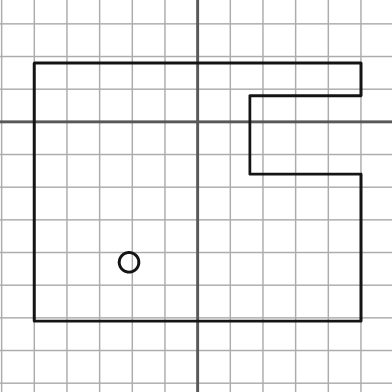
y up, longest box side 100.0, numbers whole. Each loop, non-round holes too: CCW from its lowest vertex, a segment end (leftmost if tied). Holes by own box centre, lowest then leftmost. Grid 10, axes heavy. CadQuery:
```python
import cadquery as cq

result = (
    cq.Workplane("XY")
    .moveTo(-50.0, -61.0)
    .lineTo(50.0, -61.0)
    .lineTo(50.0, -16.0)
    .lineTo(16.0, -16.0)
    .lineTo(16.0, 8.0)
    .lineTo(50.0, 8.0)
    .lineTo(50.0, 18.0)
    .lineTo(-50.0, 18.0)
    .close()
    .moveTo(-21.0, -43.0)
    .circle(3.0)
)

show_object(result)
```